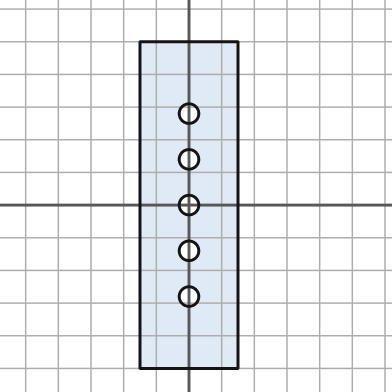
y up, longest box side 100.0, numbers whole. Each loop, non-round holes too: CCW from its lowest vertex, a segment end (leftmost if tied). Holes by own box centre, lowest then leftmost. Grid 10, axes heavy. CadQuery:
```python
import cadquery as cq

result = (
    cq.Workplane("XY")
    .moveTo(-15.0, -50.0)
    .lineTo(15.0, -50.0)
    .lineTo(15.0, 50.0)
    .lineTo(-15.0, 50.0)
    .close()
    .moveTo(0.0, -28.0)
    .circle(3.0)
    .moveTo(0.0, -14.0)
    .circle(3.0)
    .moveTo(0.0, 0.0)
    .circle(3.0)
    .moveTo(0.0, 14.0)
    .circle(3.0)
    .moveTo(0.0, 28.0)
    .circle(3.0)
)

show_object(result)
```